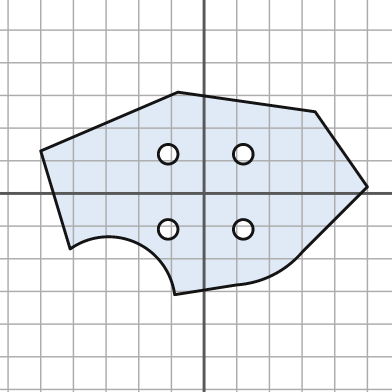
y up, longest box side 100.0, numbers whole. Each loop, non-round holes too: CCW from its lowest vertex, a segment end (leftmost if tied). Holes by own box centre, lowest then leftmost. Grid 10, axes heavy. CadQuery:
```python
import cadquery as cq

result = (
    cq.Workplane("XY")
    .moveTo(-9.0, -31.0)
    .lineTo(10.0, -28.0)
    .threePointArc((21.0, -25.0), (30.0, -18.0))
    .lineTo(50.0, 2.0)
    .lineTo(34.0, 25.0)
    .lineTo(-8.0, 31.0)
    .lineTo(-50.0, 13.0)
    .lineTo(-41.0, -17.0)
    .threePointArc((-21.0, -15.0), (-9.0, -31.0))
    .close()
    .moveTo(-11.0, -11.0)
    .circle(3.0)
    .moveTo(12.0, -11.0)
    .circle(3.0)
    .moveTo(-11.0, 12.0)
    .circle(3.0)
    .moveTo(12.0, 12.0)
    .circle(3.0)
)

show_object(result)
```